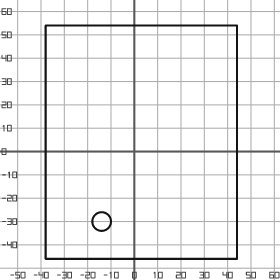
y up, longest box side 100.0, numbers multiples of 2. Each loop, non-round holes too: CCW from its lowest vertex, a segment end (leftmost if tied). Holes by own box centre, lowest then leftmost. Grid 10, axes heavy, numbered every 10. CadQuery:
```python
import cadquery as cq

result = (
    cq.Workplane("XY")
    .moveTo(-38.0, -46.0)
    .lineTo(44.0, -46.0)
    .lineTo(44.0, 54.0)
    .lineTo(-38.0, 54.0)
    .close()
    .moveTo(-14.0, -30.0)
    .circle(4.0)
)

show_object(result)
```